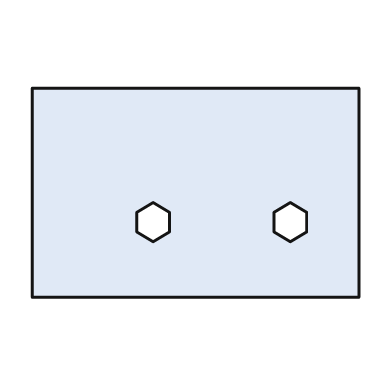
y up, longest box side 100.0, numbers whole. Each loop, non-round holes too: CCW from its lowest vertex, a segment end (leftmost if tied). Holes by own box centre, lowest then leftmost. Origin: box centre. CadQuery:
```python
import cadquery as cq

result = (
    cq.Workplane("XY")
    .moveTo(-50.0, -32.0)
    .lineTo(50.0, -32.0)
    .lineTo(50.0, 32.0)
    .lineTo(-50.0, 32.0)
    .close()
    .moveTo(-13.0, -15.0)
    .lineTo(-8.0, -12.0)
    .lineTo(-8.0, -6.0)
    .lineTo(-13.0, -3.0)
    .lineTo(-18.0, -6.0)
    .lineTo(-18.0, -12.0)
    .close()
    .moveTo(29.0, -15.0)
    .lineTo(34.0, -12.0)
    .lineTo(34.0, -6.0)
    .lineTo(29.0, -3.0)
    .lineTo(24.0, -6.0)
    .lineTo(24.0, -12.0)
    .close()
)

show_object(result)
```